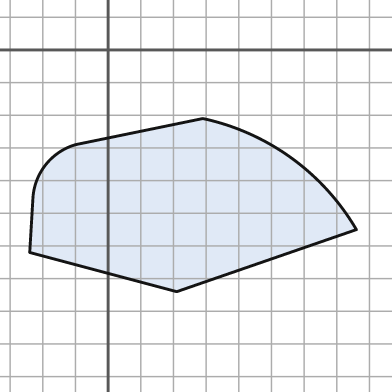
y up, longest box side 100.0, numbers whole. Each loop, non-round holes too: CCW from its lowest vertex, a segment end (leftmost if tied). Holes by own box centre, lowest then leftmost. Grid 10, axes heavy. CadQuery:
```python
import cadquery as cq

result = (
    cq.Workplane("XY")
    .moveTo(21.0, -74.0)
    .lineTo(76.0, -55.0)
    .threePointArc((56.0, -33.0), (29.0, -21.0))
    .lineTo(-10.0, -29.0)
    .threePointArc((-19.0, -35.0), (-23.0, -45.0))
    .lineTo(-24.0, -62.0)
    .close()
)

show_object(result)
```